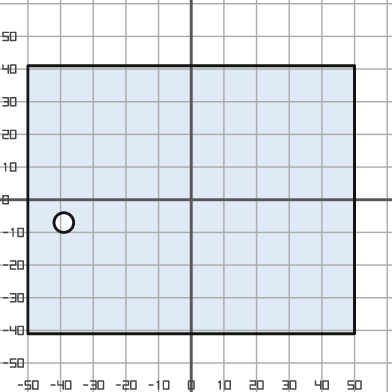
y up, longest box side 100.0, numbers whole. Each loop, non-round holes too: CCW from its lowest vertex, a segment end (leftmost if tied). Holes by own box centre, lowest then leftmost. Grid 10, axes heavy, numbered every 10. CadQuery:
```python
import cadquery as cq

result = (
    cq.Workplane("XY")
    .moveTo(-50.0, -41.0)
    .lineTo(50.0, -41.0)
    .lineTo(50.0, 41.0)
    .lineTo(-50.0, 41.0)
    .close()
    .moveTo(-39.0, -7.0)
    .circle(3.0)
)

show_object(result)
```